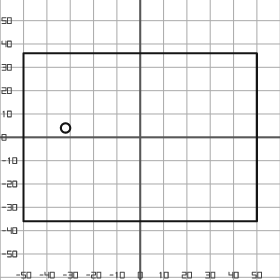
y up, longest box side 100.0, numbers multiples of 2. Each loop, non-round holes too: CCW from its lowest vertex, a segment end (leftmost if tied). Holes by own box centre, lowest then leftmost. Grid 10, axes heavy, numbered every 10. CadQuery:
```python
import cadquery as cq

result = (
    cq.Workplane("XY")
    .moveTo(-50.0, -36.0)
    .lineTo(50.0, -36.0)
    .lineTo(50.0, 36.0)
    .lineTo(-50.0, 36.0)
    .close()
    .moveTo(-32.0, 4.0)
    .circle(2.0)
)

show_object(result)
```